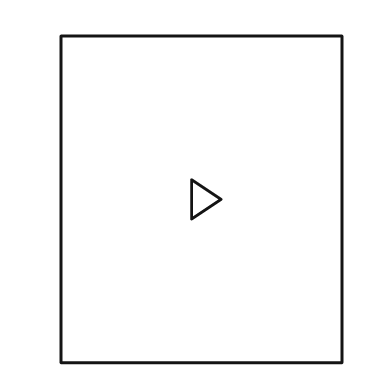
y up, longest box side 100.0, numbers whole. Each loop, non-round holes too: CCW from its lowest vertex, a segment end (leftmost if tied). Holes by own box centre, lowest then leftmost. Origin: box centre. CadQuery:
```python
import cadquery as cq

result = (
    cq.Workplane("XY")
    .moveTo(-43.0, -50.0)
    .lineTo(43.0, -50.0)
    .lineTo(43.0, 50.0)
    .lineTo(-43.0, 50.0)
    .close()
    .moveTo(-3.0, -6.0)
    .lineTo(6.0, 0.0)
    .lineTo(-3.0, 6.0)
    .close()
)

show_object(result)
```